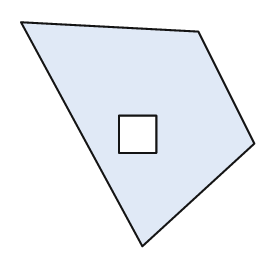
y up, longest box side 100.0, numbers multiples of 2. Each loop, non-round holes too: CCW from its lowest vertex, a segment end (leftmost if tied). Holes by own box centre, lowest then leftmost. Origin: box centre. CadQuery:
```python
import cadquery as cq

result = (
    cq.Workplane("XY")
    .moveTo(2.0, -48.0)
    .lineTo(50.0, -4.0)
    .lineTo(26.0, 44.0)
    .lineTo(-50.0, 48.0)
    .close()
    .moveTo(-8.0, -8.0)
    .lineTo(8.0, -8.0)
    .lineTo(8.0, 8.0)
    .lineTo(-8.0, 8.0)
    .close()
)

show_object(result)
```